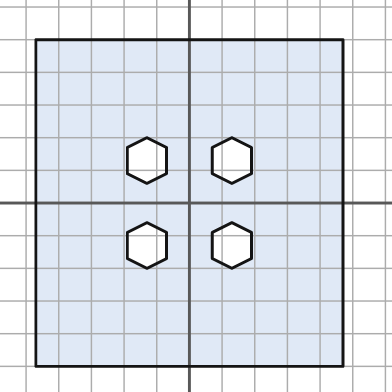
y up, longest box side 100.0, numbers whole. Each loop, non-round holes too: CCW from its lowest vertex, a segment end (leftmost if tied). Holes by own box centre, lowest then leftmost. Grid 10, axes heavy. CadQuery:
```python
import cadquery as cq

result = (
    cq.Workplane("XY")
    .moveTo(-47.0, -50.0)
    .lineTo(47.0, -50.0)
    .lineTo(47.0, 50.0)
    .lineTo(-47.0, 50.0)
    .close()
    .moveTo(-13.0, -20.0)
    .lineTo(-7.0, -17.0)
    .lineTo(-7.0, -9.0)
    .lineTo(-13.0, -6.0)
    .lineTo(-19.0, -9.0)
    .lineTo(-19.0, -17.0)
    .close()
    .moveTo(13.0, -20.0)
    .lineTo(19.0, -17.0)
    .lineTo(19.0, -9.0)
    .lineTo(13.0, -6.0)
    .lineTo(7.0, -9.0)
    .lineTo(7.0, -17.0)
    .close()
    .moveTo(-13.0, 6.0)
    .lineTo(-7.0, 9.0)
    .lineTo(-7.0, 17.0)
    .lineTo(-13.0, 20.0)
    .lineTo(-19.0, 17.0)
    .lineTo(-19.0, 9.0)
    .close()
    .moveTo(13.0, 6.0)
    .lineTo(19.0, 9.0)
    .lineTo(19.0, 17.0)
    .lineTo(13.0, 20.0)
    .lineTo(7.0, 17.0)
    .lineTo(7.0, 9.0)
    .close()
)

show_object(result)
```